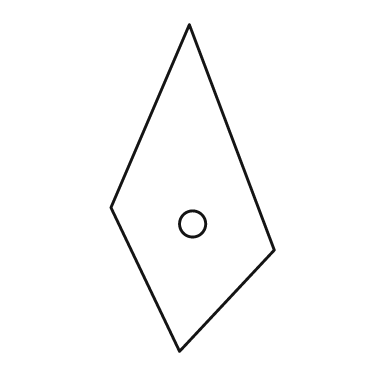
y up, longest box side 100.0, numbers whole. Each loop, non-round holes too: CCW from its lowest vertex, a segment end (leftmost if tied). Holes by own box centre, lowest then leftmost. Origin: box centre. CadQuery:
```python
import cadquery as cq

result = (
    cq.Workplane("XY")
    .moveTo(-4.0, -50.0)
    .lineTo(25.0, -19.0)
    .lineTo(-1.0, 50.0)
    .lineTo(-25.0, -6.0)
    .close()
    .moveTo(0.0, -11.0)
    .circle(4.0)
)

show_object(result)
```